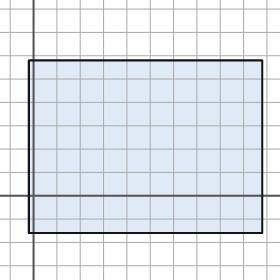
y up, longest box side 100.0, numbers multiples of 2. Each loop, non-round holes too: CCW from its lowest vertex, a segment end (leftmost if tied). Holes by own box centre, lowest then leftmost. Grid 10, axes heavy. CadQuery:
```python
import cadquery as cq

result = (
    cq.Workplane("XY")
    .moveTo(-2.0, -16.0)
    .lineTo(98.0, -16.0)
    .lineTo(98.0, 58.0)
    .lineTo(-2.0, 58.0)
    .close()
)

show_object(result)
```